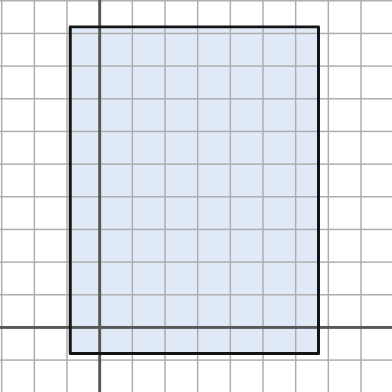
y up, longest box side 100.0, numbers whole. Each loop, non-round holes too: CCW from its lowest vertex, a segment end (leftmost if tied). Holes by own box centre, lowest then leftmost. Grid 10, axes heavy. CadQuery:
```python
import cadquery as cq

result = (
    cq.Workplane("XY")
    .moveTo(-9.0, -8.0)
    .lineTo(67.0, -8.0)
    .lineTo(67.0, 92.0)
    .lineTo(-9.0, 92.0)
    .close()
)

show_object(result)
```